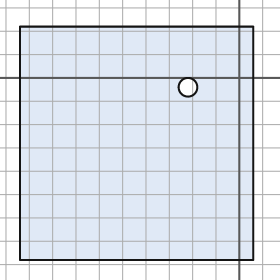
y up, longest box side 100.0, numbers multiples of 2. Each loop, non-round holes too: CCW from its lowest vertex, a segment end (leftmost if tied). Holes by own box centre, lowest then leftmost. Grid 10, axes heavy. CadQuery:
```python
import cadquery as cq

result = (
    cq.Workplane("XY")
    .moveTo(-94.0, -78.0)
    .lineTo(6.0, -78.0)
    .lineTo(6.0, 22.0)
    .lineTo(-94.0, 22.0)
    .close()
    .moveTo(-22.0, -4.0)
    .circle(4.0)
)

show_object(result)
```